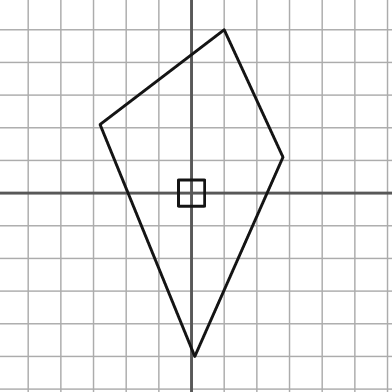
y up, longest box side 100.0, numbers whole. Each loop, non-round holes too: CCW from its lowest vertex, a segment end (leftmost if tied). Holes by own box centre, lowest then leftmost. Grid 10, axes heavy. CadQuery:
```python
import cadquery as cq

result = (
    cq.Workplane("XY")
    .moveTo(1.0, -50.0)
    .lineTo(28.0, 11.0)
    .lineTo(10.0, 50.0)
    .lineTo(-28.0, 21.0)
    .close()
    .moveTo(-4.0, -4.0)
    .lineTo(4.0, -4.0)
    .lineTo(4.0, 4.0)
    .lineTo(-4.0, 4.0)
    .close()
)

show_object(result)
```